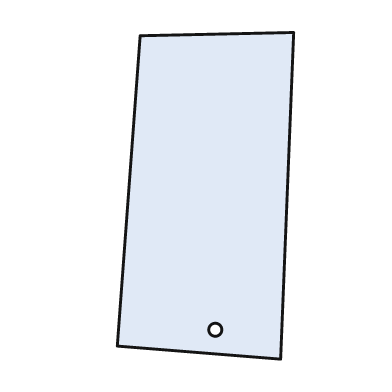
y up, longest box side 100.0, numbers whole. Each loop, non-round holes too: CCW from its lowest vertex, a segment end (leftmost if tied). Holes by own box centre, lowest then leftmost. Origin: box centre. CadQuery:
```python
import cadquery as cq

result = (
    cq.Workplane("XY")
    .moveTo(23.0, -50.0)
    .lineTo(27.0, 50.0)
    .lineTo(-20.0, 49.0)
    .lineTo(-27.0, -46.0)
    .close()
    .moveTo(3.0, -41.0)
    .circle(2.0)
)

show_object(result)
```